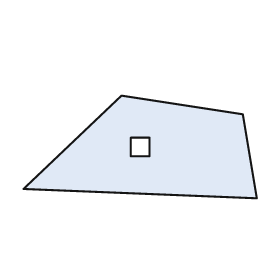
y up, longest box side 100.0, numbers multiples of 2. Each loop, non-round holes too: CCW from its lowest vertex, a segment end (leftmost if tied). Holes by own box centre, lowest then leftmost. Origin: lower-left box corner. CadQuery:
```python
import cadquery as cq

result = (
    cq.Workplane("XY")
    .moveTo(100.0, 0.0)
    .lineTo(94.0, 36.0)
    .lineTo(42.0, 44.0)
    .lineTo(0.0, 4.0)
    .close()
    .moveTo(46.0, 18.0)
    .lineTo(54.0, 18.0)
    .lineTo(54.0, 26.0)
    .lineTo(46.0, 26.0)
    .close()
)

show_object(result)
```